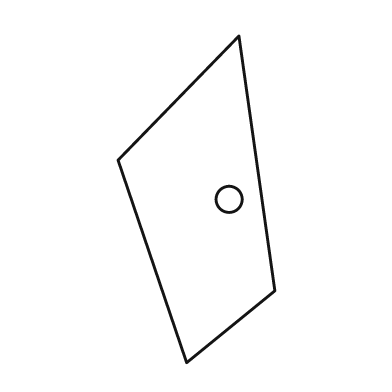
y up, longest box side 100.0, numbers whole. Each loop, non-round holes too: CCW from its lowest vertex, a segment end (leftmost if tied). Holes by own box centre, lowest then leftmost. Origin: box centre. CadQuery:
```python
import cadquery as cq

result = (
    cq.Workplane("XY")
    .moveTo(-3.0, -50.0)
    .lineTo(24.0, -28.0)
    .lineTo(13.0, 50.0)
    .lineTo(-24.0, 12.0)
    .close()
    .moveTo(10.0, 0.0)
    .circle(4.0)
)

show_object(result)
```